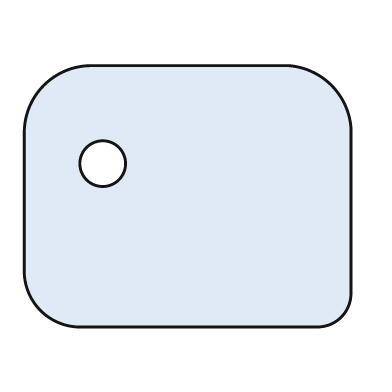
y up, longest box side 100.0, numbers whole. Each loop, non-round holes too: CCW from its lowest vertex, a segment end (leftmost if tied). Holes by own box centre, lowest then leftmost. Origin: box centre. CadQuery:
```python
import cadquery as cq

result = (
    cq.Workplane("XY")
    .moveTo(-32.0, -40.0)
    .lineTo(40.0, -40.0)
    .threePointArc((47.0, -37.0), (50.0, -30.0))
    .lineTo(50.0, 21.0)
    .threePointArc((44.0, 34.0), (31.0, 40.0))
    .lineTo(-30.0, 40.0)
    .threePointArc((-44.0, 34.0), (-50.0, 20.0))
    .lineTo(-50.0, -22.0)
    .threePointArc((-45.0, -35.0), (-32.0, -40.0))
    .close()
    .moveTo(-26.0, 10.0)
    .circle(7.0)
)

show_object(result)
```